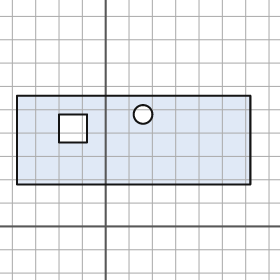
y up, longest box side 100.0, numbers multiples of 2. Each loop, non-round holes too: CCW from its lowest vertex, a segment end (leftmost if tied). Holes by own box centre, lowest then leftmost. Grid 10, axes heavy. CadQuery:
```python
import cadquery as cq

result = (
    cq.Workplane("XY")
    .moveTo(-38.0, 18.0)
    .lineTo(62.0, 18.0)
    .lineTo(62.0, 56.0)
    .lineTo(-38.0, 56.0)
    .close()
    .moveTo(-20.0, 36.0)
    .lineTo(-8.0, 36.0)
    .lineTo(-8.0, 48.0)
    .lineTo(-20.0, 48.0)
    .close()
    .moveTo(16.0, 48.0)
    .circle(4.0)
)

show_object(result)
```